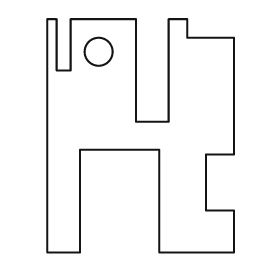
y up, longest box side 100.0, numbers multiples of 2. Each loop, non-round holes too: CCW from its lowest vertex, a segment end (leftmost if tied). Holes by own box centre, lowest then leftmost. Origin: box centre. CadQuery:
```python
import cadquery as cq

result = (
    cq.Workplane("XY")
    .moveTo(-40.0, -50.0)
    .lineTo(-26.0, -50.0)
    .lineTo(-26.0, -6.0)
    .lineTo(8.0, -6.0)
    .lineTo(8.0, -50.0)
    .lineTo(40.0, -50.0)
    .lineTo(40.0, -32.0)
    .lineTo(28.0, -32.0)
    .lineTo(28.0, -8.0)
    .lineTo(40.0, -8.0)
    .lineTo(40.0, 42.0)
    .lineTo(20.0, 42.0)
    .lineTo(20.0, 50.0)
    .lineTo(12.0, 50.0)
    .lineTo(12.0, 6.0)
    .lineTo(-2.0, 6.0)
    .lineTo(-2.0, 50.0)
    .lineTo(-30.0, 50.0)
    .lineTo(-30.0, 28.0)
    .lineTo(-36.0, 28.0)
    .lineTo(-36.0, 50.0)
    .lineTo(-40.0, 50.0)
    .close()
    .moveTo(-18.0, 36.0)
    .circle(6.0)
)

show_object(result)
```